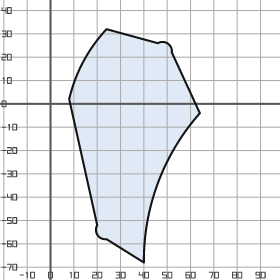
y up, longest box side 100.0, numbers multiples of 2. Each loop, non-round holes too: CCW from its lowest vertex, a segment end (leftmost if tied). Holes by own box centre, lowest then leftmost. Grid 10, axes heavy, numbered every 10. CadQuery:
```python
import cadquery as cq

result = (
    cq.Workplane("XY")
    .moveTo(40.0, -68.0)
    .threePointArc((46.0, -34.0), (64.0, -4.0))
    .lineTo(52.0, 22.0)
    .threePointArc((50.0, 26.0), (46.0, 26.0))
    .lineTo(24.0, 32.0)
    .threePointArc((14.0, 18.0), (8.0, 2.0))
    .lineTo(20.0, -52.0)
    .threePointArc((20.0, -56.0), (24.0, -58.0))
    .close()
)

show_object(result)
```